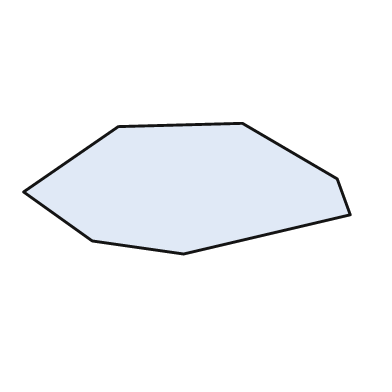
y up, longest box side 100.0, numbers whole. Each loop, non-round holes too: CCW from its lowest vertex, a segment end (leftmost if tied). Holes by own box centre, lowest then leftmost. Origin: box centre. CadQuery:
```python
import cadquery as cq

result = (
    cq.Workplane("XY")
    .moveTo(-1.0, -20.0)
    .lineTo(50.0, -8.0)
    .lineTo(46.0, 3.0)
    .lineTo(17.0, 20.0)
    .lineTo(-21.0, 19.0)
    .lineTo(-50.0, -1.0)
    .lineTo(-29.0, -16.0)
    .close()
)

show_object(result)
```